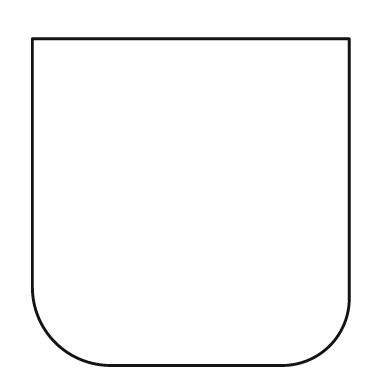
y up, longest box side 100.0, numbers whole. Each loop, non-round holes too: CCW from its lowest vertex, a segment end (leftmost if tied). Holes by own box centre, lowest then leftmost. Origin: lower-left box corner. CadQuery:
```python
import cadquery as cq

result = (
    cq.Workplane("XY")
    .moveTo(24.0, 0.0)
    .lineTo(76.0, 0.0)
    .threePointArc((91.0, 6.0), (97.0, 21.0))
    .lineTo(97.0, 100.0)
    .lineTo(0.0, 100.0)
    .lineTo(0.0, 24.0)
    .threePointArc((7.0, 7.0), (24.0, 0.0))
    .close()
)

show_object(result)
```